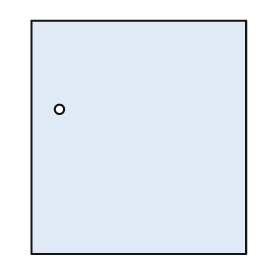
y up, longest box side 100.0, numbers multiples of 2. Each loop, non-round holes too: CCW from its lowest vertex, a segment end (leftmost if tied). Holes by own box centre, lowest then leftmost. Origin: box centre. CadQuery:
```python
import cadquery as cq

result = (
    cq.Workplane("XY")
    .moveTo(-46.0, -50.0)
    .lineTo(46.0, -50.0)
    .lineTo(46.0, 50.0)
    .lineTo(-46.0, 50.0)
    .close()
    .moveTo(-34.0, 12.0)
    .circle(2.0)
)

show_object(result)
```